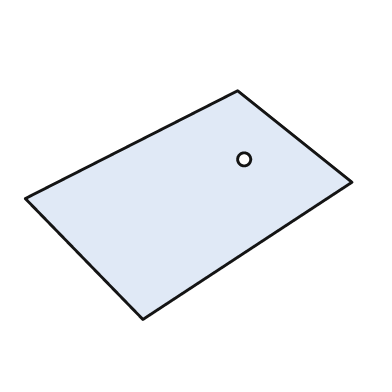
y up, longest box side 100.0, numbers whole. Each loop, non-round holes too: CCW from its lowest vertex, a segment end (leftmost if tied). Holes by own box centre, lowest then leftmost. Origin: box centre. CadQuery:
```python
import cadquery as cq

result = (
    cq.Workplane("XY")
    .moveTo(-14.0, -35.0)
    .lineTo(50.0, 7.0)
    .lineTo(15.0, 35.0)
    .lineTo(-50.0, 2.0)
    .close()
    .moveTo(17.0, 14.0)
    .circle(2.0)
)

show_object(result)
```